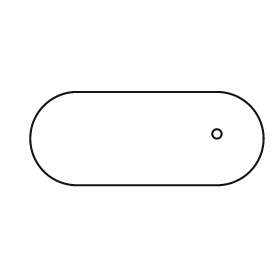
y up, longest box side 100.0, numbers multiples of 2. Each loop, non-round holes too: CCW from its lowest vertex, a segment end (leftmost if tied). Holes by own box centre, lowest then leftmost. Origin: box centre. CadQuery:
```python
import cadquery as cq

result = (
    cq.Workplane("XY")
    .moveTo(-30.0, -20.0)
    .lineTo(30.0, -20.0)
    .threePointArc((50.0, 0.0), (30.0, 20.0))
    .lineTo(-30.0, 20.0)
    .threePointArc((-50.0, 0.0), (-30.0, -20.0))
    .close()
    .moveTo(30.0, 2.0)
    .circle(2.0)
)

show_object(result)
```